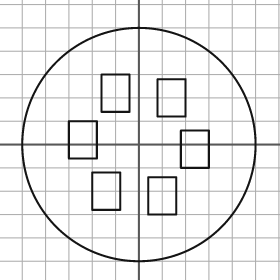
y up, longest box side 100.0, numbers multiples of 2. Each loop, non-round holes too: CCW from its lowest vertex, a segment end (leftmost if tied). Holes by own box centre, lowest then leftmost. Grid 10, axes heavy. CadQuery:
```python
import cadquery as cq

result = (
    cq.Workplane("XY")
    .moveTo(0.0, 0.0)
    .circle(50.0)
    .moveTo(4.0, -30.0)
    .lineTo(16.0, -30.0)
    .lineTo(16.0, -14.0)
    .lineTo(4.0, -14.0)
    .close()
    .moveTo(-20.0, -28.0)
    .lineTo(-8.0, -28.0)
    .lineTo(-8.0, -12.0)
    .lineTo(-20.0, -12.0)
    .close()
    .moveTo(18.0, -10.0)
    .lineTo(30.0, -10.0)
    .lineTo(30.0, 6.0)
    .lineTo(18.0, 6.0)
    .close()
    .moveTo(-30.0, -6.0)
    .lineTo(-18.0, -6.0)
    .lineTo(-18.0, 10.0)
    .lineTo(-30.0, 10.0)
    .close()
    .moveTo(8.0, 12.0)
    .lineTo(20.0, 12.0)
    .lineTo(20.0, 28.0)
    .lineTo(8.0, 28.0)
    .close()
    .moveTo(-16.0, 14.0)
    .lineTo(-4.0, 14.0)
    .lineTo(-4.0, 30.0)
    .lineTo(-16.0, 30.0)
    .close()
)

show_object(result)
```